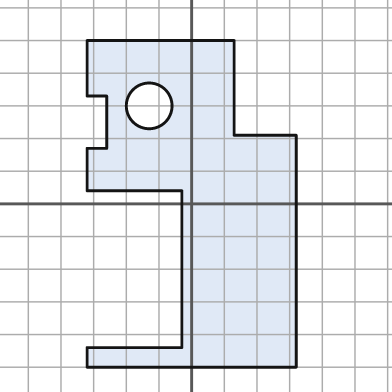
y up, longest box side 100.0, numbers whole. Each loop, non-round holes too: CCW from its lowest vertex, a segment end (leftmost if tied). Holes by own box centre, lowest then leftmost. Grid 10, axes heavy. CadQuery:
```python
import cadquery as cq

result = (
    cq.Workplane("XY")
    .moveTo(-32.0, -50.0)
    .lineTo(32.0, -50.0)
    .lineTo(32.0, 21.0)
    .lineTo(13.0, 21.0)
    .lineTo(13.0, 50.0)
    .lineTo(-32.0, 50.0)
    .lineTo(-32.0, 33.0)
    .lineTo(-26.0, 33.0)
    .lineTo(-26.0, 17.0)
    .lineTo(-32.0, 17.0)
    .lineTo(-32.0, 4.0)
    .lineTo(-3.0, 4.0)
    .lineTo(-3.0, -44.0)
    .lineTo(-32.0, -44.0)
    .close()
    .moveTo(-13.0, 30.0)
    .circle(7.0)
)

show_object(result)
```